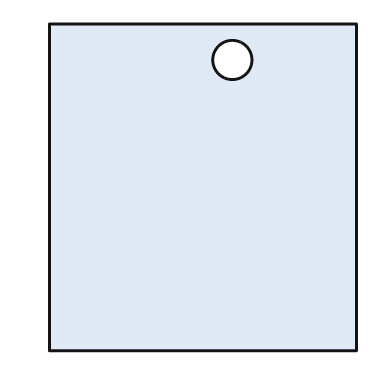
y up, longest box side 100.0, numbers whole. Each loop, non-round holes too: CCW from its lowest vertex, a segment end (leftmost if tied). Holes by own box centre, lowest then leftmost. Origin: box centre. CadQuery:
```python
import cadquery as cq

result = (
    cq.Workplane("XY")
    .moveTo(-47.0, -50.0)
    .lineTo(47.0, -50.0)
    .lineTo(47.0, 50.0)
    .lineTo(-47.0, 50.0)
    .close()
    .moveTo(9.0, 39.0)
    .circle(6.0)
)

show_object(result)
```